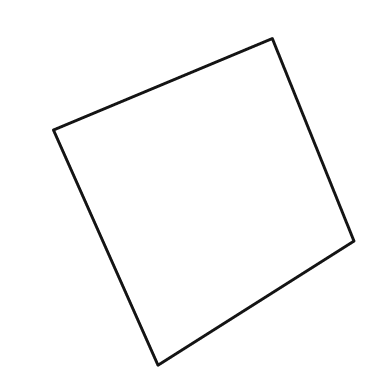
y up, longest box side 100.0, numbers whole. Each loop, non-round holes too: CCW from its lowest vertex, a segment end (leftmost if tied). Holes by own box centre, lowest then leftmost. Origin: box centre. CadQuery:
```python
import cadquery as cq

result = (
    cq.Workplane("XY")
    .moveTo(-14.0, -50.0)
    .lineTo(46.0, -12.0)
    .lineTo(21.0, 50.0)
    .lineTo(-46.0, 22.0)
    .close()
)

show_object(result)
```